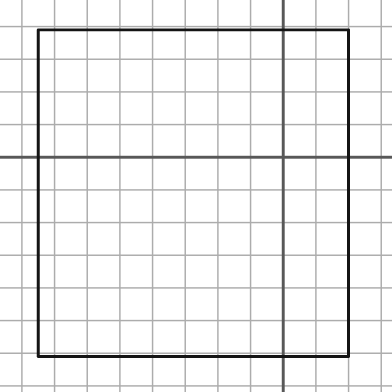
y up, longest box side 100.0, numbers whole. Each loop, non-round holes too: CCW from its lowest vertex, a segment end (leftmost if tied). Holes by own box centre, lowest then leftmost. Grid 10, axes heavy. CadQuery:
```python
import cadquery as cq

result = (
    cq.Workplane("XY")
    .moveTo(-75.0, -61.0)
    .lineTo(20.0, -61.0)
    .lineTo(20.0, 39.0)
    .lineTo(-75.0, 39.0)
    .close()
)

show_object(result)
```